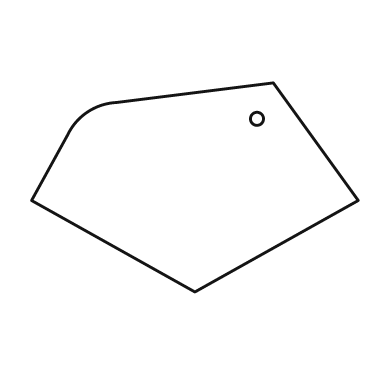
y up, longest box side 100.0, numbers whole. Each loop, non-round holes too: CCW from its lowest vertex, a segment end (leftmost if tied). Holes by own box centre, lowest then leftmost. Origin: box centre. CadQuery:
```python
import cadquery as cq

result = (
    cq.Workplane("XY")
    .moveTo(0.0, -32.0)
    .lineTo(50.0, -4.0)
    .lineTo(24.0, 32.0)
    .lineTo(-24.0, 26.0)
    .threePointArc((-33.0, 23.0), (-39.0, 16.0))
    .lineTo(-50.0, -4.0)
    .close()
    .moveTo(19.0, 21.0)
    .circle(2.0)
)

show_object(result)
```